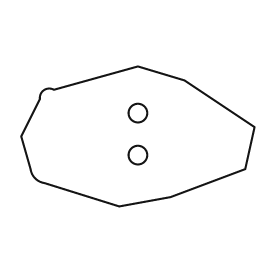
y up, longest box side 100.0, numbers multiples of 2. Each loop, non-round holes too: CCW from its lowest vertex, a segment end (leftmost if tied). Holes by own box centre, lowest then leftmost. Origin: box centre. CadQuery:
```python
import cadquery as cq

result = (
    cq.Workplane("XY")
    .moveTo(-8.0, -30.0)
    .lineTo(14.0, -26.0)
    .lineTo(46.0, -14.0)
    .lineTo(50.0, 4.0)
    .lineTo(20.0, 24.0)
    .lineTo(0.0, 30.0)
    .lineTo(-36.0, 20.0)
    .threePointArc((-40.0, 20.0), (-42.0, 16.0))
    .lineTo(-50.0, 0.0)
    .lineTo(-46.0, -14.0)
    .threePointArc((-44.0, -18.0), (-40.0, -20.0))
    .close()
    .moveTo(0.0, -8.0)
    .circle(4.0)
    .moveTo(0.0, 10.0)
    .circle(4.0)
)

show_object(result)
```